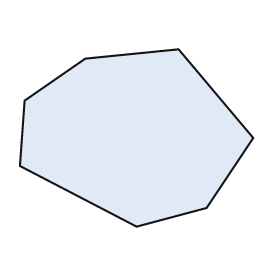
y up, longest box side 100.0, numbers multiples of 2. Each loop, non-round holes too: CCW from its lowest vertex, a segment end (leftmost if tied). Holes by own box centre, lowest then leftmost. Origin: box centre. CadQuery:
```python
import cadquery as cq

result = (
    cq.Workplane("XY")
    .moveTo(0.0, -38.0)
    .lineTo(30.0, -30.0)
    .lineTo(50.0, 0.0)
    .lineTo(18.0, 38.0)
    .lineTo(-22.0, 34.0)
    .lineTo(-48.0, 16.0)
    .lineTo(-50.0, -12.0)
    .close()
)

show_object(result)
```